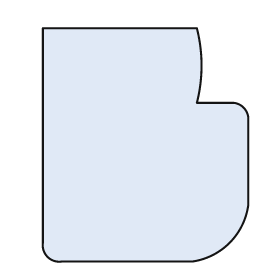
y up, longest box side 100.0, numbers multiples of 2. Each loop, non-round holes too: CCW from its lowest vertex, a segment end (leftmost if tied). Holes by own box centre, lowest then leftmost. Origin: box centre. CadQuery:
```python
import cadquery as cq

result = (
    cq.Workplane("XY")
    .moveTo(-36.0, -50.0)
    .lineTo(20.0, -50.0)
    .threePointArc((36.0, -42.0), (44.0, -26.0))
    .lineTo(44.0, 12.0)
    .threePointArc((42.0, 16.0), (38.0, 18.0))
    .lineTo(22.0, 18.0)
    .threePointArc((24.0, 34.0), (22.0, 50.0))
    .lineTo(-44.0, 50.0)
    .lineTo(-44.0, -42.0)
    .threePointArc((-42.0, -48.0), (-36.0, -50.0))
    .close()
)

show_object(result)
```